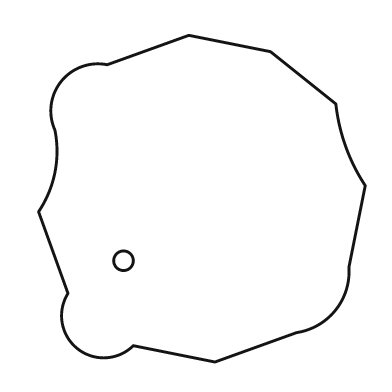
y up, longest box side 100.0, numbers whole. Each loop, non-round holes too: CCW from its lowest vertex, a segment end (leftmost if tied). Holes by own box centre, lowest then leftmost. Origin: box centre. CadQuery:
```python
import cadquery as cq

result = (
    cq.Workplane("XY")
    .moveTo(4.0, -50.0)
    .lineTo(29.0, -41.0)
    .threePointArc((41.0, -34.0), (45.0, -21.0))
    .lineTo(50.0, 4.0)
    .threePointArc((44.0, 16.0), (41.0, 29.0))
    .lineTo(21.0, 45.0)
    .lineTo(-4.0, 50.0)
    .lineTo(-29.0, 41.0)
    .threePointArc((-43.0, 36.0), (-45.0, 21.0))
    .threePointArc((-45.0, 8.0), (-50.0, -4.0))
    .lineTo(-41.0, -29.0)
    .threePointArc((-38.0, -46.0), (-21.0, -45.0))
    .close()
    .moveTo(-24.0, -19.0)
    .circle(3.0)
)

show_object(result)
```